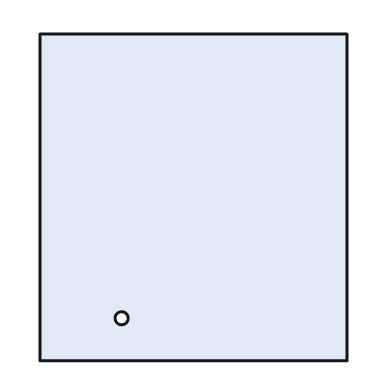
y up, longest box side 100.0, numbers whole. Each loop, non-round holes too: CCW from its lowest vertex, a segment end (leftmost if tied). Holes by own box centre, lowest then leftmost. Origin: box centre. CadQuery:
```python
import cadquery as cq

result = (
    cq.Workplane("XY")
    .moveTo(-47.0, -50.0)
    .lineTo(47.0, -50.0)
    .lineTo(47.0, 50.0)
    .lineTo(-47.0, 50.0)
    .close()
    .moveTo(-22.0, -37.0)
    .circle(2.0)
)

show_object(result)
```